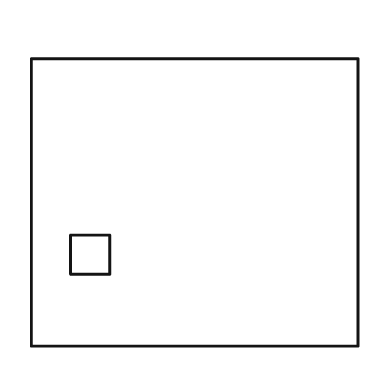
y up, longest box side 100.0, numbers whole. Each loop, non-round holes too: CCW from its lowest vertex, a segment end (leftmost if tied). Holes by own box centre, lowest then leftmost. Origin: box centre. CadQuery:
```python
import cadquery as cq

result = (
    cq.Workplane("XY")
    .moveTo(-50.0, -44.0)
    .lineTo(50.0, -44.0)
    .lineTo(50.0, 44.0)
    .lineTo(-50.0, 44.0)
    .close()
    .moveTo(-38.0, -22.0)
    .lineTo(-26.0, -22.0)
    .lineTo(-26.0, -10.0)
    .lineTo(-38.0, -10.0)
    .close()
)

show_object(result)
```